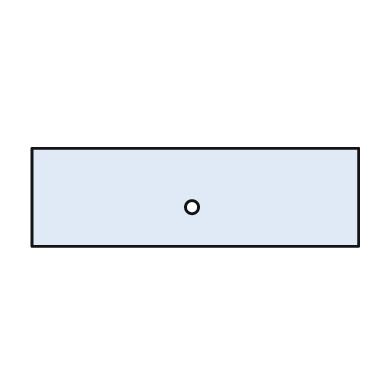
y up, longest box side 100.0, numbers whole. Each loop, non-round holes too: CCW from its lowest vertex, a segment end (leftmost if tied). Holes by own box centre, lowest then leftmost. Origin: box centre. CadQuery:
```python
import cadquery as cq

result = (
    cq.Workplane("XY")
    .moveTo(-50.0, -15.0)
    .lineTo(50.0, -15.0)
    .lineTo(50.0, 15.0)
    .lineTo(-50.0, 15.0)
    .close()
    .moveTo(-1.0, -3.0)
    .circle(2.0)
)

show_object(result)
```